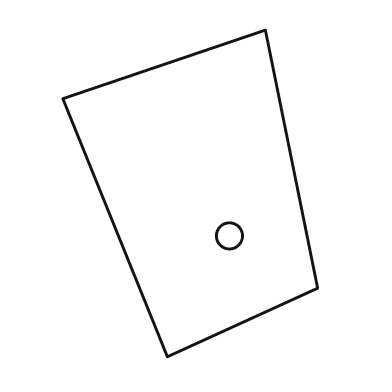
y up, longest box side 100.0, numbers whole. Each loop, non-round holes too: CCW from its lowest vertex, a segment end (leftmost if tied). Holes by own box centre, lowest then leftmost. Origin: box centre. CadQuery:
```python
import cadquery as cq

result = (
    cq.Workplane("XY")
    .moveTo(-7.0, -50.0)
    .lineTo(39.0, -29.0)
    .lineTo(23.0, 50.0)
    .lineTo(-39.0, 29.0)
    .close()
    .moveTo(12.0, -13.0)
    .circle(4.0)
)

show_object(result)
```